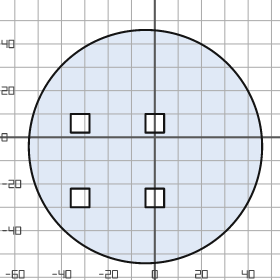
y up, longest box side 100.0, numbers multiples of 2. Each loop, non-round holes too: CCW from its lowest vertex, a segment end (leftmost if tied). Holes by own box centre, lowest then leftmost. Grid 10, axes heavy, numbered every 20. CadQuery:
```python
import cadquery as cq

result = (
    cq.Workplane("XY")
    .moveTo(-4.0, -4.0)
    .circle(50.0)
    .moveTo(-36.0, -30.0)
    .lineTo(-28.0, -30.0)
    .lineTo(-28.0, -22.0)
    .lineTo(-36.0, -22.0)
    .close()
    .moveTo(-4.0, -30.0)
    .lineTo(4.0, -30.0)
    .lineTo(4.0, -22.0)
    .lineTo(-4.0, -22.0)
    .close()
    .moveTo(-36.0, 2.0)
    .lineTo(-28.0, 2.0)
    .lineTo(-28.0, 10.0)
    .lineTo(-36.0, 10.0)
    .close()
    .moveTo(-4.0, 2.0)
    .lineTo(4.0, 2.0)
    .lineTo(4.0, 10.0)
    .lineTo(-4.0, 10.0)
    .close()
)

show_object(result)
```